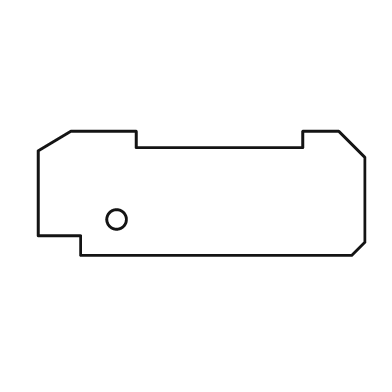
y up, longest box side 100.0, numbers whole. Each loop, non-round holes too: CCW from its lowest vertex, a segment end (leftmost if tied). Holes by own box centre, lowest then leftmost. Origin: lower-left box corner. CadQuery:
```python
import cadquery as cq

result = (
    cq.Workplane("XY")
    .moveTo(13.0, 0.0)
    .lineTo(96.0, 0.0)
    .lineTo(100.0, 4.0)
    .lineTo(100.0, 30.0)
    .lineTo(92.0, 38.0)
    .lineTo(81.0, 38.0)
    .lineTo(81.0, 33.0)
    .lineTo(30.0, 33.0)
    .lineTo(30.0, 38.0)
    .lineTo(10.0, 38.0)
    .lineTo(0.0, 32.0)
    .lineTo(0.0, 6.0)
    .lineTo(13.0, 6.0)
    .close()
    .moveTo(24.0, 11.0)
    .circle(3.0)
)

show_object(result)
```